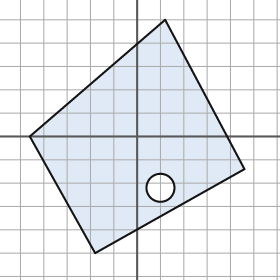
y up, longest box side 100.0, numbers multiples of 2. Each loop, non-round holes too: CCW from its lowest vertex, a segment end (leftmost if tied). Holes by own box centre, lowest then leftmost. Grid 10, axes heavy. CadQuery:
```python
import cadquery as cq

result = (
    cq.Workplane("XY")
    .moveTo(-18.0, -50.0)
    .lineTo(46.0, -14.0)
    .lineTo(12.0, 50.0)
    .lineTo(-46.0, 0.0)
    .close()
    .moveTo(10.0, -22.0)
    .circle(6.0)
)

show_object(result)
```